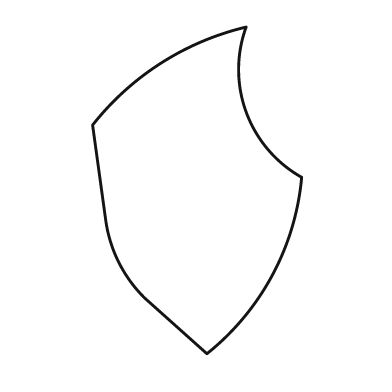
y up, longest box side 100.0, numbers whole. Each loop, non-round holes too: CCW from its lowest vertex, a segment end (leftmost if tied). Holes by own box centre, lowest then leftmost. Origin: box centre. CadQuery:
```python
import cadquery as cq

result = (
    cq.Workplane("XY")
    .moveTo(3.0, -50.0)
    .threePointArc((23.0, -26.0), (32.0, 4.0))
    .threePointArc((15.0, 24.0), (15.0, 50.0))
    .threePointArc((-11.0, 39.0), (-32.0, 20.0))
    .lineTo(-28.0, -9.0)
    .threePointArc((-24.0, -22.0), (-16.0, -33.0))
    .close()
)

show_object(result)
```